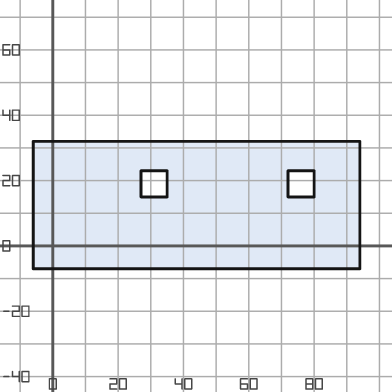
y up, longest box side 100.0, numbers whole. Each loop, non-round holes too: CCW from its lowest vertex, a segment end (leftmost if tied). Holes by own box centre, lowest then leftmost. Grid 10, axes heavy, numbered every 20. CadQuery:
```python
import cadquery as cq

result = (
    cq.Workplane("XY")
    .moveTo(-6.0, -7.0)
    .lineTo(94.0, -7.0)
    .lineTo(94.0, 32.0)
    .lineTo(-6.0, 32.0)
    .close()
    .moveTo(27.0, 15.0)
    .lineTo(35.0, 15.0)
    .lineTo(35.0, 23.0)
    .lineTo(27.0, 23.0)
    .close()
    .moveTo(72.0, 15.0)
    .lineTo(80.0, 15.0)
    .lineTo(80.0, 23.0)
    .lineTo(72.0, 23.0)
    .close()
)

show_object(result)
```